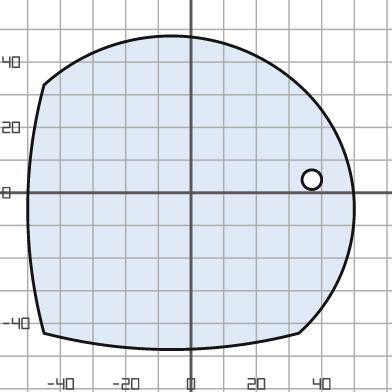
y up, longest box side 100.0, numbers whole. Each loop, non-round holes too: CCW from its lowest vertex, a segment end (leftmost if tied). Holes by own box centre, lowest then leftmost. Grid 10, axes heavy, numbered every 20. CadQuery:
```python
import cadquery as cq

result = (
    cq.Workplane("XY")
    .moveTo(-45.0, -43.0)
    .threePointArc((-6.0, -48.0), (33.0, -43.0))
    .threePointArc((50.0, -5.0), (33.0, 33.0))
    .threePointArc((-6.0, 48.0), (-45.0, 33.0))
    .threePointArc((-50.0, -5.0), (-45.0, -43.0))
    .close()
    .moveTo(37.0, 4.0)
    .circle(3.0)
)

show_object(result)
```